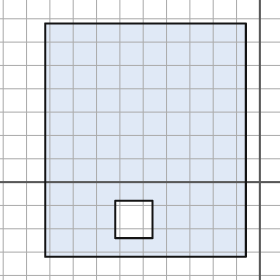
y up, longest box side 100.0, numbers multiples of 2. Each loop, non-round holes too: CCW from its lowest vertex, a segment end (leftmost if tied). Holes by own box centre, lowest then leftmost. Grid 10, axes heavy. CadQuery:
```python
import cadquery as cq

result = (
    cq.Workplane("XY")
    .moveTo(-92.0, -32.0)
    .lineTo(-6.0, -32.0)
    .lineTo(-6.0, 68.0)
    .lineTo(-92.0, 68.0)
    .close()
    .moveTo(-62.0, -24.0)
    .lineTo(-46.0, -24.0)
    .lineTo(-46.0, -8.0)
    .lineTo(-62.0, -8.0)
    .close()
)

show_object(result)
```